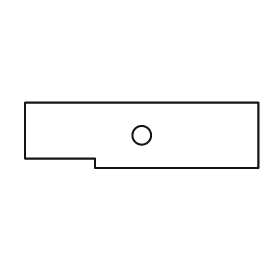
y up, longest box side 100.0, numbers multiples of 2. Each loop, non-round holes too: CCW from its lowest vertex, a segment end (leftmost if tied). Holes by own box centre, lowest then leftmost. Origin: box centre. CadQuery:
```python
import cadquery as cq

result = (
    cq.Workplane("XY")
    .moveTo(-20.0, -14.0)
    .lineTo(50.0, -14.0)
    .lineTo(50.0, 14.0)
    .lineTo(-50.0, 14.0)
    .lineTo(-50.0, -10.0)
    .lineTo(-20.0, -10.0)
    .close()
    .moveTo(0.0, 0.0)
    .circle(4.0)
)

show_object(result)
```